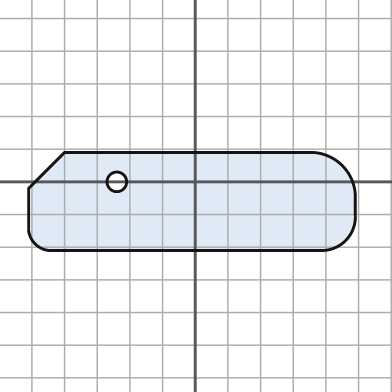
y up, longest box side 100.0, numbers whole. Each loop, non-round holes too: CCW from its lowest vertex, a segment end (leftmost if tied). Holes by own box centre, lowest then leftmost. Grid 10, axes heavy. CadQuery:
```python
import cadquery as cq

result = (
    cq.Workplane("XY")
    .moveTo(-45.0, -21.0)
    .lineTo(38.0, -21.0)
    .threePointArc((46.0, -18.0), (49.0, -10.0))
    .lineTo(49.0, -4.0)
    .threePointArc((45.0, 5.0), (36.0, 9.0))
    .lineTo(-40.0, 9.0)
    .lineTo(-51.0, -2.0)
    .lineTo(-51.0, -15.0)
    .threePointArc((-49.0, -19.0), (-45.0, -21.0))
    .close()
    .moveTo(-24.0, 0.0)
    .circle(3.0)
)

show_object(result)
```